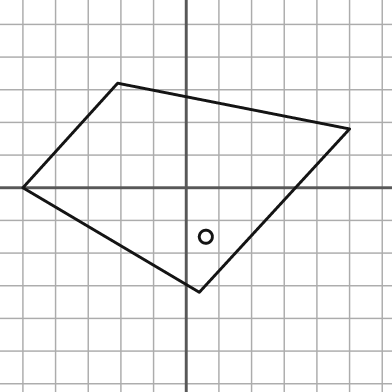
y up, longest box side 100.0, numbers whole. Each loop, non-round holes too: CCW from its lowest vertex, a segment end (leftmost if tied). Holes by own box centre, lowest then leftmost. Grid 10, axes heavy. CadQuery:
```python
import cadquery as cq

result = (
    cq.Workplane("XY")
    .moveTo(4.0, -32.0)
    .lineTo(50.0, 18.0)
    .lineTo(-21.0, 32.0)
    .lineTo(-50.0, 0.0)
    .close()
    .moveTo(6.0, -15.0)
    .circle(2.0)
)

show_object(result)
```